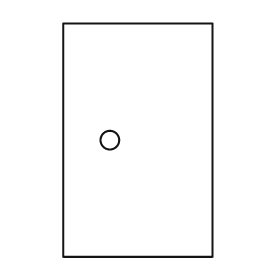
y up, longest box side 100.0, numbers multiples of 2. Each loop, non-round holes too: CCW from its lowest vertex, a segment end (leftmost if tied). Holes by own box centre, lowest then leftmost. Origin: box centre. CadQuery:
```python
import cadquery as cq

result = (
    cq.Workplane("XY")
    .moveTo(-32.0, -50.0)
    .lineTo(32.0, -50.0)
    .lineTo(32.0, 50.0)
    .lineTo(-32.0, 50.0)
    .close()
    .moveTo(-12.0, 0.0)
    .circle(4.0)
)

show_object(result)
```